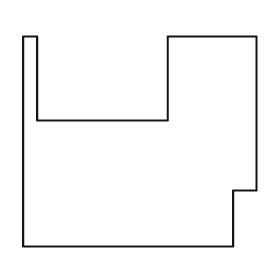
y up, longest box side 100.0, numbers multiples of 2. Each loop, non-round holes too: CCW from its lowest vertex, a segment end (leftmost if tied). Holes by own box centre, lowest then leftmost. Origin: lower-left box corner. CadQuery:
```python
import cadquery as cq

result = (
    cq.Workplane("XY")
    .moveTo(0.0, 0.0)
    .lineTo(90.0, 0.0)
    .lineTo(90.0, 24.0)
    .lineTo(100.0, 24.0)
    .lineTo(100.0, 90.0)
    .lineTo(62.0, 90.0)
    .lineTo(62.0, 54.0)
    .lineTo(6.0, 54.0)
    .lineTo(6.0, 90.0)
    .lineTo(0.0, 90.0)
    .close()
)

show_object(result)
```